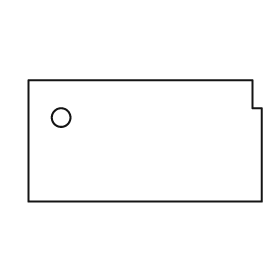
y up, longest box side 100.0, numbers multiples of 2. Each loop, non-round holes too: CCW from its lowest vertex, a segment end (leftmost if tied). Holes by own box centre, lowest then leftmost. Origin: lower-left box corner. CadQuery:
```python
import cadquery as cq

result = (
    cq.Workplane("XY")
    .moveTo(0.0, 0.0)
    .lineTo(100.0, 0.0)
    .lineTo(100.0, 40.0)
    .lineTo(96.0, 40.0)
    .lineTo(96.0, 52.0)
    .lineTo(0.0, 52.0)
    .close()
    .moveTo(14.0, 36.0)
    .circle(4.0)
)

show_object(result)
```